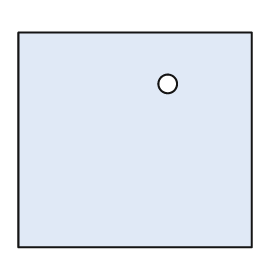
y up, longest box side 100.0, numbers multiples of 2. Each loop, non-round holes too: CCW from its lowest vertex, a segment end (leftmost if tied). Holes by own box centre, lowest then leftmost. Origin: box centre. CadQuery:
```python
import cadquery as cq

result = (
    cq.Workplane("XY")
    .moveTo(-50.0, -46.0)
    .lineTo(50.0, -46.0)
    .lineTo(50.0, 46.0)
    .lineTo(-50.0, 46.0)
    .close()
    .moveTo(14.0, 24.0)
    .circle(4.0)
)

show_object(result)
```